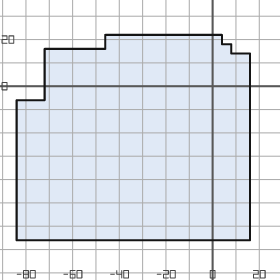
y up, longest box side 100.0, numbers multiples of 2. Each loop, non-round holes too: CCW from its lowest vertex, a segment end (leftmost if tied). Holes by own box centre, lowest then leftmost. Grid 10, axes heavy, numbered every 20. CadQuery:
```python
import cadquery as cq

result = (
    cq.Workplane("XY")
    .moveTo(-84.0, -66.0)
    .lineTo(16.0, -66.0)
    .lineTo(16.0, 14.0)
    .lineTo(8.0, 14.0)
    .lineTo(8.0, 18.0)
    .lineTo(4.0, 18.0)
    .lineTo(4.0, 22.0)
    .lineTo(-46.0, 22.0)
    .lineTo(-46.0, 16.0)
    .lineTo(-72.0, 16.0)
    .lineTo(-72.0, -6.0)
    .lineTo(-84.0, -6.0)
    .close()
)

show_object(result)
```